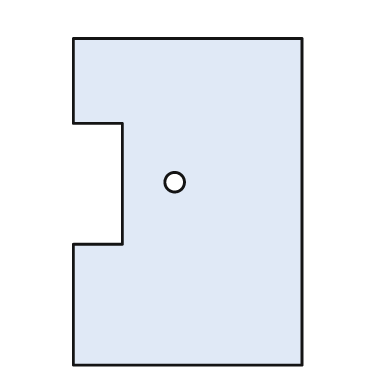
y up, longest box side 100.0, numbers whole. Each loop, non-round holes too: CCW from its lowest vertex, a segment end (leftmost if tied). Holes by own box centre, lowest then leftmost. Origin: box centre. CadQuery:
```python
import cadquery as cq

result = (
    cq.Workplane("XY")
    .moveTo(-35.0, -50.0)
    .lineTo(35.0, -50.0)
    .lineTo(35.0, 50.0)
    .lineTo(-35.0, 50.0)
    .lineTo(-35.0, 24.0)
    .lineTo(-20.0, 24.0)
    .lineTo(-20.0, -13.0)
    .lineTo(-35.0, -13.0)
    .close()
    .moveTo(-4.0, 6.0)
    .circle(3.0)
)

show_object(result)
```